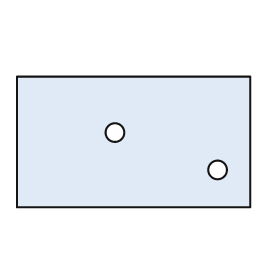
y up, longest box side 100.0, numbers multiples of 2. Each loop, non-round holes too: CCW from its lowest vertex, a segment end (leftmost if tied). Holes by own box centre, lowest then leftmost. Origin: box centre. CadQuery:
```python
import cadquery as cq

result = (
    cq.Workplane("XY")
    .moveTo(-50.0, -28.0)
    .lineTo(50.0, -28.0)
    .lineTo(50.0, 28.0)
    .lineTo(-50.0, 28.0)
    .close()
    .moveTo(36.0, -12.0)
    .circle(4.0)
    .moveTo(-8.0, 4.0)
    .circle(4.0)
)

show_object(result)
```